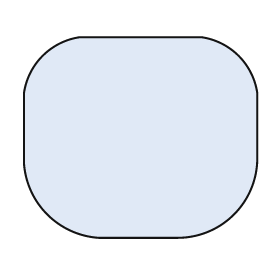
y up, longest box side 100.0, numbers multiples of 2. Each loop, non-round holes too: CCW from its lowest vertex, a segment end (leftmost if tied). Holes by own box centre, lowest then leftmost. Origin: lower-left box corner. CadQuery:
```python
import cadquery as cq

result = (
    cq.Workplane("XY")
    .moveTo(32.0, 0.0)
    .lineTo(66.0, 0.0)
    .threePointArc((90.0, 10.0), (100.0, 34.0))
    .lineTo(100.0, 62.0)
    .threePointArc((92.0, 78.0), (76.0, 86.0))
    .lineTo(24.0, 86.0)
    .threePointArc((8.0, 78.0), (0.0, 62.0))
    .lineTo(0.0, 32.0)
    .threePointArc((10.0, 10.0), (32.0, 0.0))
    .close()
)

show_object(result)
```